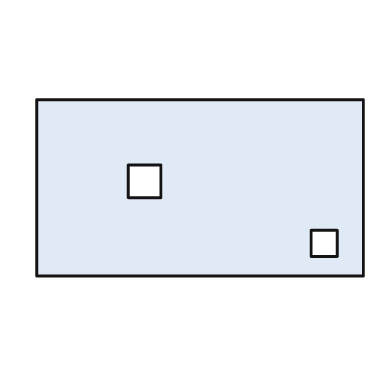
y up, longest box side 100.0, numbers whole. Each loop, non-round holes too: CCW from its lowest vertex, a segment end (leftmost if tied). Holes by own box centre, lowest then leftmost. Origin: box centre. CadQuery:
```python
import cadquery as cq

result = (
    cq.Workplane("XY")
    .moveTo(-50.0, -27.0)
    .lineTo(50.0, -27.0)
    .lineTo(50.0, 27.0)
    .lineTo(-50.0, 27.0)
    .close()
    .moveTo(34.0, -21.0)
    .lineTo(42.0, -21.0)
    .lineTo(42.0, -13.0)
    .lineTo(34.0, -13.0)
    .close()
    .moveTo(-22.0, -3.0)
    .lineTo(-12.0, -3.0)
    .lineTo(-12.0, 7.0)
    .lineTo(-22.0, 7.0)
    .close()
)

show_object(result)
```